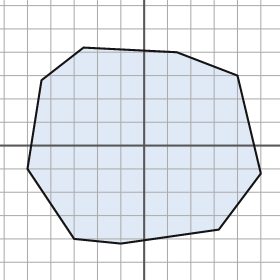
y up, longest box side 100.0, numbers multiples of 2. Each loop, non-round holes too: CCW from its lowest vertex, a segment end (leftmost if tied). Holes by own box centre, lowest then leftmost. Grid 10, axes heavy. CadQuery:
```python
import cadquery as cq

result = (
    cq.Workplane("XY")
    .moveTo(-10.0, -42.0)
    .lineTo(32.0, -36.0)
    .lineTo(50.0, -12.0)
    .lineTo(40.0, 30.0)
    .lineTo(14.0, 40.0)
    .lineTo(-26.0, 42.0)
    .lineTo(-44.0, 28.0)
    .lineTo(-50.0, -10.0)
    .lineTo(-30.0, -40.0)
    .close()
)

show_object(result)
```